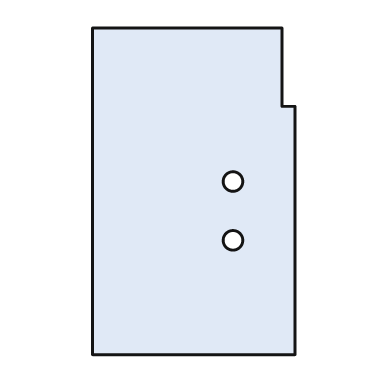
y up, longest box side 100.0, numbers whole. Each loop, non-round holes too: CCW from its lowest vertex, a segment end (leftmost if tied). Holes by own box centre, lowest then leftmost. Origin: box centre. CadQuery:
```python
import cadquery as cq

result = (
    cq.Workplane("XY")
    .moveTo(-31.0, -50.0)
    .lineTo(31.0, -50.0)
    .lineTo(31.0, 26.0)
    .lineTo(27.0, 26.0)
    .lineTo(27.0, 50.0)
    .lineTo(-31.0, 50.0)
    .close()
    .moveTo(12.0, -15.0)
    .circle(3.0)
    .moveTo(12.0, 3.0)
    .circle(3.0)
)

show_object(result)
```